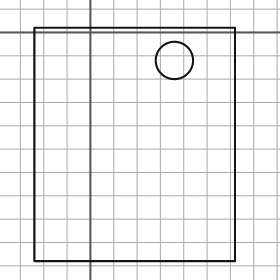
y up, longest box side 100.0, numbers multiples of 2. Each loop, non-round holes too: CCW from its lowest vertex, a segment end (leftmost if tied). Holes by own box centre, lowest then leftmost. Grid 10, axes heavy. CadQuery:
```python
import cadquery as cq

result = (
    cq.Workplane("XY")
    .moveTo(-24.0, -98.0)
    .lineTo(62.0, -98.0)
    .lineTo(62.0, 2.0)
    .lineTo(-24.0, 2.0)
    .close()
    .moveTo(36.0, -12.0)
    .circle(8.0)
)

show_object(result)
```